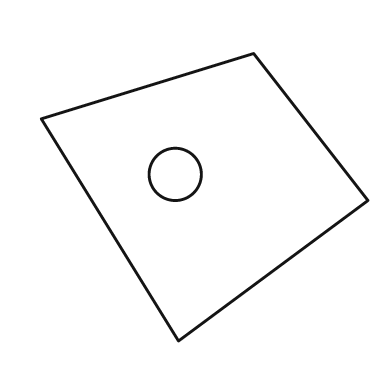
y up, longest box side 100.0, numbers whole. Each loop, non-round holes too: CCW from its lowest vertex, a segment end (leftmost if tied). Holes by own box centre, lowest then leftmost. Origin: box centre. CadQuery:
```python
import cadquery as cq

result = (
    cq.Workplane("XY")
    .moveTo(-8.0, -44.0)
    .lineTo(50.0, -1.0)
    .lineTo(15.0, 44.0)
    .lineTo(-50.0, 24.0)
    .close()
    .moveTo(-9.0, 7.0)
    .circle(8.0)
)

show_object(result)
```